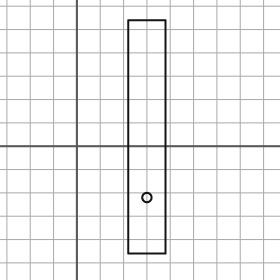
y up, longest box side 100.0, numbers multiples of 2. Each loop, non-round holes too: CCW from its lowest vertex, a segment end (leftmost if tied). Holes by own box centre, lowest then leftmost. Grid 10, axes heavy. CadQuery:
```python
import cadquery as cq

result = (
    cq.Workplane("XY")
    .moveTo(22.0, -46.0)
    .lineTo(38.0, -46.0)
    .lineTo(38.0, 54.0)
    .lineTo(22.0, 54.0)
    .close()
    .moveTo(30.0, -22.0)
    .circle(2.0)
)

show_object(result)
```